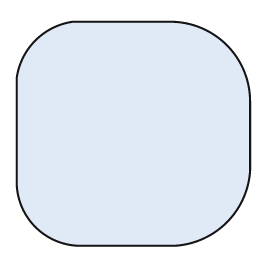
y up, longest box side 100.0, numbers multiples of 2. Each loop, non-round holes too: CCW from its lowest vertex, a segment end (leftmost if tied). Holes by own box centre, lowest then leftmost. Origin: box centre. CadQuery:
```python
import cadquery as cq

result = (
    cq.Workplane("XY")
    .moveTo(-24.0, -48.0)
    .lineTo(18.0, -48.0)
    .threePointArc((40.0, -38.0), (50.0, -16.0))
    .lineTo(50.0, 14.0)
    .threePointArc((40.0, 38.0), (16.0, 48.0))
    .lineTo(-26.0, 48.0)
    .threePointArc((-42.0, 40.0), (-50.0, 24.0))
    .lineTo(-50.0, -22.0)
    .threePointArc((-42.0, -40.0), (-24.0, -48.0))
    .close()
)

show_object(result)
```